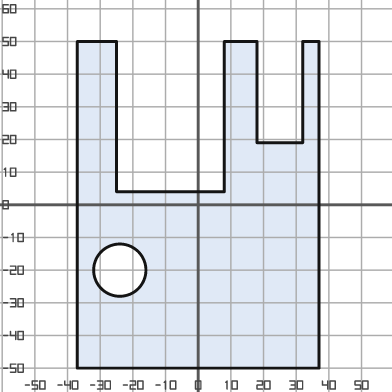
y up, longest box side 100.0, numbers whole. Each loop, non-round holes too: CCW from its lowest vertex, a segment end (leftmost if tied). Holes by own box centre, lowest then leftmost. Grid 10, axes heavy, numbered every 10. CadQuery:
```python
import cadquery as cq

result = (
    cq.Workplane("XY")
    .moveTo(-37.0, -50.0)
    .lineTo(37.0, -50.0)
    .lineTo(37.0, 50.0)
    .lineTo(32.0, 50.0)
    .lineTo(32.0, 19.0)
    .lineTo(18.0, 19.0)
    .lineTo(18.0, 50.0)
    .lineTo(8.0, 50.0)
    .lineTo(8.0, 4.0)
    .lineTo(-25.0, 4.0)
    .lineTo(-25.0, 50.0)
    .lineTo(-37.0, 50.0)
    .close()
    .moveTo(-24.0, -20.0)
    .circle(8.0)
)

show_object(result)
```